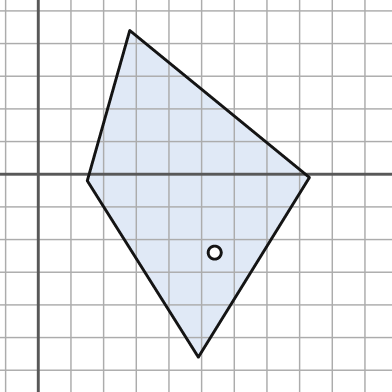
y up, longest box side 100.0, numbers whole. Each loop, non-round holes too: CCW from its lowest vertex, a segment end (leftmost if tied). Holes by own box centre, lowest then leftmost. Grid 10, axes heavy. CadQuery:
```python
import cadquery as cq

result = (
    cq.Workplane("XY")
    .moveTo(49.0, -56.0)
    .lineTo(83.0, -1.0)
    .lineTo(28.0, 44.0)
    .lineTo(15.0, -2.0)
    .close()
    .moveTo(54.0, -24.0)
    .circle(2.0)
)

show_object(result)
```